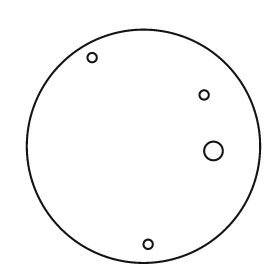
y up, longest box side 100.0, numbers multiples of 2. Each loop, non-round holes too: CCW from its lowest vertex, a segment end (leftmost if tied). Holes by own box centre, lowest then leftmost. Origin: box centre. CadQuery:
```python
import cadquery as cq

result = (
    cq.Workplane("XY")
    .moveTo(0.0, 0.0)
    .circle(50.0)
    .moveTo(2.0, -42.0)
    .circle(2.0)
    .moveTo(30.0, -2.0)
    .circle(4.0)
    .moveTo(26.0, 22.0)
    .circle(2.0)
    .moveTo(-22.0, 38.0)
    .circle(2.0)
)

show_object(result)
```